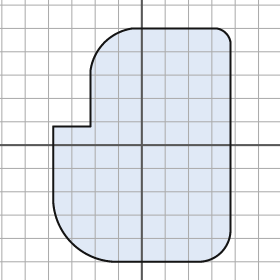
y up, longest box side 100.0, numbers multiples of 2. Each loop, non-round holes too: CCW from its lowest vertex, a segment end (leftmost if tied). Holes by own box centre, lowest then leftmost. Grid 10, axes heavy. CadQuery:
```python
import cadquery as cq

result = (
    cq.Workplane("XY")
    .moveTo(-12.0, -50.0)
    .lineTo(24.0, -50.0)
    .threePointArc((34.0, -46.0), (38.0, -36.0))
    .lineTo(38.0, 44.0)
    .threePointArc((36.0, 48.0), (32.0, 50.0))
    .lineTo(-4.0, 50.0)
    .threePointArc((-16.0, 44.0), (-22.0, 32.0))
    .lineTo(-22.0, 8.0)
    .lineTo(-38.0, 8.0)
    .lineTo(-38.0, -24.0)
    .threePointArc((-30.0, -42.0), (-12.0, -50.0))
    .close()
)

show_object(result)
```